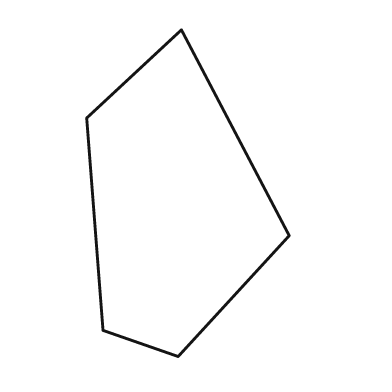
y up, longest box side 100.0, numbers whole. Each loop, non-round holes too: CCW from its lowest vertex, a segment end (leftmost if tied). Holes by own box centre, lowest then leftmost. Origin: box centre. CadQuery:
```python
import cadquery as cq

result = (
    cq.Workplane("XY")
    .moveTo(-3.0, -50.0)
    .lineTo(31.0, -13.0)
    .lineTo(-2.0, 50.0)
    .lineTo(-31.0, 23.0)
    .lineTo(-26.0, -42.0)
    .close()
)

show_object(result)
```